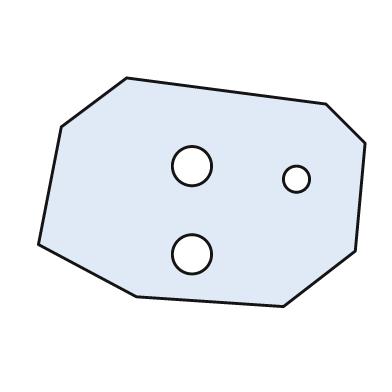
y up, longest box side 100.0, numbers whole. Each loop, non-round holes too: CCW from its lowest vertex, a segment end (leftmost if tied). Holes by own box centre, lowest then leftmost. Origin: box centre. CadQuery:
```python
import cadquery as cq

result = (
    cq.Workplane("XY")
    .moveTo(25.0, -35.0)
    .lineTo(47.0, -18.0)
    .lineTo(50.0, 15.0)
    .lineTo(38.0, 27.0)
    .lineTo(-23.0, 35.0)
    .lineTo(-43.0, 20.0)
    .lineTo(-50.0, -16.0)
    .lineTo(-20.0, -32.0)
    .close()
    .moveTo(-3.0, -19.0)
    .circle(6.0)
    .moveTo(29.0, 4.0)
    .circle(4.0)
    .moveTo(-3.0, 8.0)
    .circle(6.0)
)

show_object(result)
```